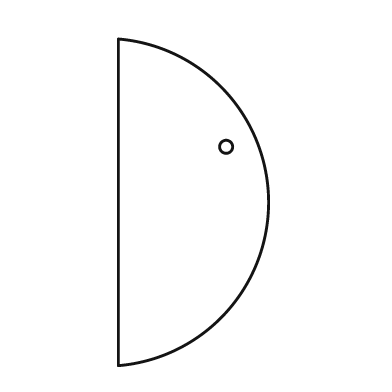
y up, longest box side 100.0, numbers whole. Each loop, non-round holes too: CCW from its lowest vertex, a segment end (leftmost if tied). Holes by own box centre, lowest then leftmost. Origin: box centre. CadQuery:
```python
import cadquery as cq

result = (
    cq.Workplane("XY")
    .moveTo(-23.0, -50.0)
    .threePointArc((23.0, 0.0), (-23.0, 50.0))
    .close()
    .moveTo(10.0, 17.0)
    .circle(2.0)
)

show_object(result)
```